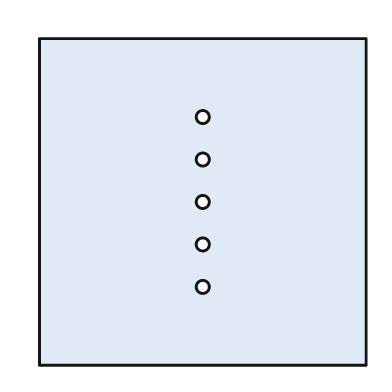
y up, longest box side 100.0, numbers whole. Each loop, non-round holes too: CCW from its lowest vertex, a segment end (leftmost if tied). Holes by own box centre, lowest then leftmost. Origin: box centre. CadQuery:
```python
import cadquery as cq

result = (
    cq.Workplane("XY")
    .moveTo(-50.0, -50.0)
    .lineTo(50.0, -50.0)
    .lineTo(50.0, 50.0)
    .lineTo(-50.0, 50.0)
    .close()
    .moveTo(0.0, -26.0)
    .circle(2.0)
    .moveTo(0.0, -13.0)
    .circle(2.0)
    .moveTo(0.0, 0.0)
    .circle(2.0)
    .moveTo(0.0, 13.0)
    .circle(2.0)
    .moveTo(0.0, 26.0)
    .circle(2.0)
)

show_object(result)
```